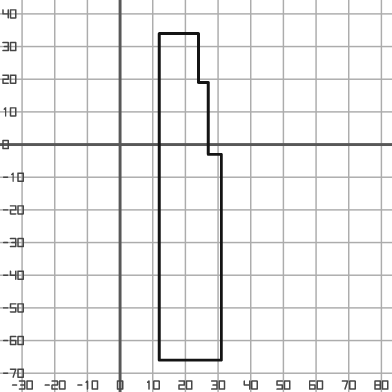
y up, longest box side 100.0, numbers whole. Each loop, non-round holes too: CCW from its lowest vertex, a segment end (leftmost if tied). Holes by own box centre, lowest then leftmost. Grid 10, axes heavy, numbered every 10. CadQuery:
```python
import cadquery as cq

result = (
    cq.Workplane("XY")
    .moveTo(12.0, -66.0)
    .lineTo(31.0, -66.0)
    .lineTo(31.0, -3.0)
    .lineTo(27.0, -3.0)
    .lineTo(27.0, 19.0)
    .lineTo(24.0, 19.0)
    .lineTo(24.0, 34.0)
    .lineTo(12.0, 34.0)
    .close()
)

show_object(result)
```